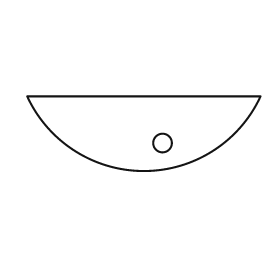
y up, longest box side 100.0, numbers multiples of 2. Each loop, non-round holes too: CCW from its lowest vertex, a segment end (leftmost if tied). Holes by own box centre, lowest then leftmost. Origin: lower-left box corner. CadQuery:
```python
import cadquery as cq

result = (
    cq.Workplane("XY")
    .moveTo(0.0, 32.0)
    .threePointArc((50.0, 0.0), (100.0, 32.0))
    .close()
    .moveTo(58.0, 12.0)
    .circle(4.0)
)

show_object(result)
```